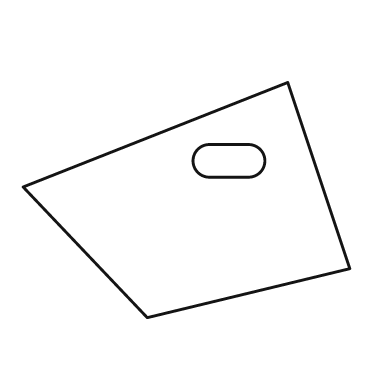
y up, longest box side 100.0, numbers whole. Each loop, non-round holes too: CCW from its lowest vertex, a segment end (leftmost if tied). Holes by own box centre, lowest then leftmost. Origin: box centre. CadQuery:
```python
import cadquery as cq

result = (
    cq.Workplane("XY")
    .moveTo(-12.0, -36.0)
    .lineTo(50.0, -21.0)
    .lineTo(31.0, 36.0)
    .lineTo(-50.0, 4.0)
    .close()
    .moveTo(7.0, 7.0)
    .lineTo(19.0, 7.0)
    .threePointArc((24.0, 12.0), (19.0, 17.0))
    .lineTo(7.0, 17.0)
    .threePointArc((2.0, 12.0), (7.0, 7.0))
    .close()
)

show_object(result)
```